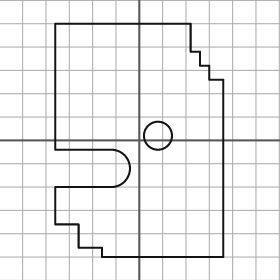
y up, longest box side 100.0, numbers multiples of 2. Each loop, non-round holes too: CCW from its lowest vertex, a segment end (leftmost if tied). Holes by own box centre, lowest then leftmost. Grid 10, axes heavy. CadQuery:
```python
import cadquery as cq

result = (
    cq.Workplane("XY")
    .moveTo(-16.0, -50.0)
    .lineTo(36.0, -50.0)
    .lineTo(36.0, 26.0)
    .lineTo(30.0, 26.0)
    .lineTo(30.0, 32.0)
    .lineTo(26.0, 32.0)
    .lineTo(26.0, 38.0)
    .lineTo(22.0, 38.0)
    .lineTo(22.0, 50.0)
    .lineTo(-36.0, 50.0)
    .lineTo(-36.0, -4.0)
    .lineTo(-12.0, -4.0)
    .threePointArc((-4.0, -12.0), (-12.0, -20.0))
    .lineTo(-36.0, -20.0)
    .lineTo(-36.0, -36.0)
    .lineTo(-26.0, -36.0)
    .lineTo(-26.0, -46.0)
    .lineTo(-16.0, -46.0)
    .close()
    .moveTo(8.0, 2.0)
    .circle(6.0)
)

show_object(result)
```